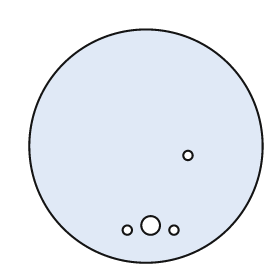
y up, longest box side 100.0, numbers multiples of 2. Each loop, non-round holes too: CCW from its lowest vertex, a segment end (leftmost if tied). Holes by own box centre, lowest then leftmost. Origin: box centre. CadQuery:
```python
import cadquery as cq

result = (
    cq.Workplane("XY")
    .moveTo(0.0, 0.0)
    .circle(50.0)
    .moveTo(-8.0, -36.0)
    .circle(2.0)
    .moveTo(12.0, -36.0)
    .circle(2.0)
    .moveTo(2.0, -34.0)
    .circle(4.0)
    .moveTo(18.0, -4.0)
    .circle(2.0)
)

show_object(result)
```